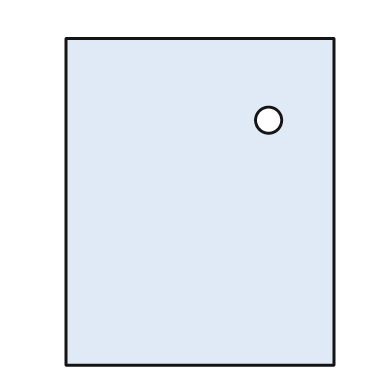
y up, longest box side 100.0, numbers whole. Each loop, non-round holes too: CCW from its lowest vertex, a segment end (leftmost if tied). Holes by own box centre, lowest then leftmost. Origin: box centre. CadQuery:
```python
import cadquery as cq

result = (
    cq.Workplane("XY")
    .moveTo(-41.0, -50.0)
    .lineTo(41.0, -50.0)
    .lineTo(41.0, 50.0)
    .lineTo(-41.0, 50.0)
    .close()
    .moveTo(21.0, 25.0)
    .circle(4.0)
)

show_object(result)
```